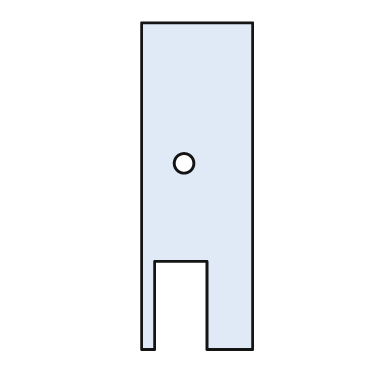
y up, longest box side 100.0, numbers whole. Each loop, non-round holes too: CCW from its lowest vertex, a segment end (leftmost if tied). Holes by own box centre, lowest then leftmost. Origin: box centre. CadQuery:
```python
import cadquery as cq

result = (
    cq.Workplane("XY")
    .moveTo(-17.0, -50.0)
    .lineTo(-13.0, -50.0)
    .lineTo(-13.0, -23.0)
    .lineTo(3.0, -23.0)
    .lineTo(3.0, -50.0)
    .lineTo(17.0, -50.0)
    .lineTo(17.0, 50.0)
    .lineTo(-17.0, 50.0)
    .close()
    .moveTo(-4.0, 7.0)
    .circle(3.0)
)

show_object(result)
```